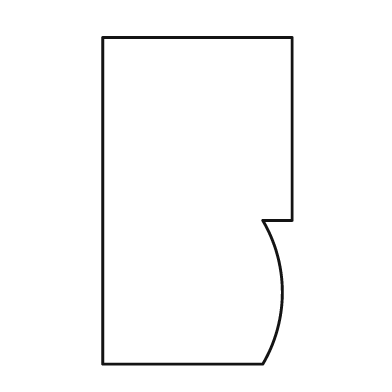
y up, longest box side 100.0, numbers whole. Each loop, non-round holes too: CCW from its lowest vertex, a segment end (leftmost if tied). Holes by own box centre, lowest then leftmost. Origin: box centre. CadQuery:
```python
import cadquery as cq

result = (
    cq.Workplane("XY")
    .moveTo(-29.0, -50.0)
    .lineTo(20.0, -50.0)
    .threePointArc((26.0, -28.0), (20.0, -6.0))
    .lineTo(29.0, -6.0)
    .lineTo(29.0, 50.0)
    .lineTo(-29.0, 50.0)
    .close()
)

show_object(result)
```